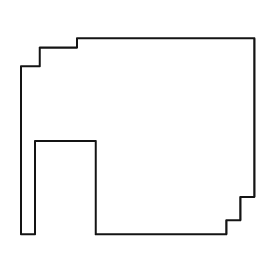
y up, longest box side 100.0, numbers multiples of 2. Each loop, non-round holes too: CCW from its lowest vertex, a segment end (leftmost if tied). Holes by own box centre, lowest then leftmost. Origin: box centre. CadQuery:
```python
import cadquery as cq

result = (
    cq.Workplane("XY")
    .moveTo(-50.0, -42.0)
    .lineTo(-44.0, -42.0)
    .lineTo(-44.0, -2.0)
    .lineTo(-18.0, -2.0)
    .lineTo(-18.0, -42.0)
    .lineTo(38.0, -42.0)
    .lineTo(38.0, -36.0)
    .lineTo(44.0, -36.0)
    .lineTo(44.0, -26.0)
    .lineTo(50.0, -26.0)
    .lineTo(50.0, 42.0)
    .lineTo(-26.0, 42.0)
    .lineTo(-26.0, 38.0)
    .lineTo(-42.0, 38.0)
    .lineTo(-42.0, 30.0)
    .lineTo(-50.0, 30.0)
    .close()
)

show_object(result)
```